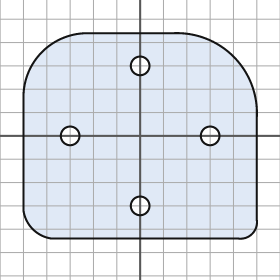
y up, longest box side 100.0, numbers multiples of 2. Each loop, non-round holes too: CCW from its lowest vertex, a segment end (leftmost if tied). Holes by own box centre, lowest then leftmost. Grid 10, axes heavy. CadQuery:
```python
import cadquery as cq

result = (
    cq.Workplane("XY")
    .moveTo(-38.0, -44.0)
    .lineTo(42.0, -44.0)
    .threePointArc((48.0, -42.0), (50.0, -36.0))
    .lineTo(50.0, 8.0)
    .threePointArc((40.0, 34.0), (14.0, 44.0))
    .lineTo(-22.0, 44.0)
    .threePointArc((-42.0, 36.0), (-50.0, 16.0))
    .lineTo(-50.0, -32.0)
    .threePointArc((-46.0, -40.0), (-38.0, -44.0))
    .close()
    .moveTo(0.0, -30.0)
    .circle(4.0)
    .moveTo(-30.0, 0.0)
    .circle(4.0)
    .moveTo(30.0, 0.0)
    .circle(4.0)
    .moveTo(0.0, 30.0)
    .circle(4.0)
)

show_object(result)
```